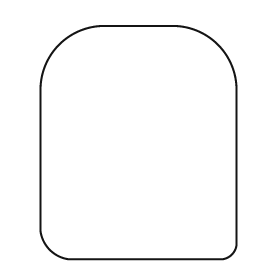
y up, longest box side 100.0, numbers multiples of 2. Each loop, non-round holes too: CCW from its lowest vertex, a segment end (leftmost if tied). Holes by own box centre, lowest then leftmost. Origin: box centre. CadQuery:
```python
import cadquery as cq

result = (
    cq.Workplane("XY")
    .moveTo(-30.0, -50.0)
    .lineTo(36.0, -50.0)
    .threePointArc((40.0, -48.0), (42.0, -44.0))
    .lineTo(42.0, 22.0)
    .threePointArc((34.0, 42.0), (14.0, 50.0))
    .lineTo(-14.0, 50.0)
    .threePointArc((-34.0, 42.0), (-42.0, 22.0))
    .lineTo(-42.0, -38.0)
    .threePointArc((-38.0, -46.0), (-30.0, -50.0))
    .close()
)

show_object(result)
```